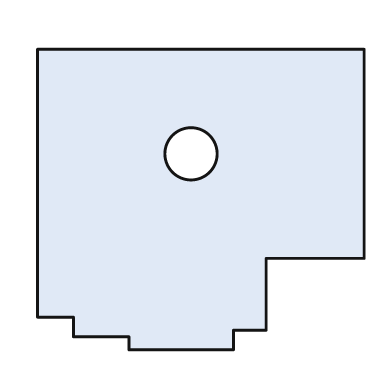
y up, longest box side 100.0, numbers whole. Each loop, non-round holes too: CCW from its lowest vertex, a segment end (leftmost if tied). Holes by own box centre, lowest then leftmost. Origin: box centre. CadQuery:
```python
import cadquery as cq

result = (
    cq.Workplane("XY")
    .moveTo(-22.0, -46.0)
    .lineTo(10.0, -46.0)
    .lineTo(10.0, -40.0)
    .lineTo(20.0, -40.0)
    .lineTo(20.0, -18.0)
    .lineTo(50.0, -18.0)
    .lineTo(50.0, 46.0)
    .lineTo(-50.0, 46.0)
    .lineTo(-50.0, -36.0)
    .lineTo(-39.0, -36.0)
    .lineTo(-39.0, -42.0)
    .lineTo(-22.0, -42.0)
    .close()
    .moveTo(-3.0, 14.0)
    .circle(8.0)
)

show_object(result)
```